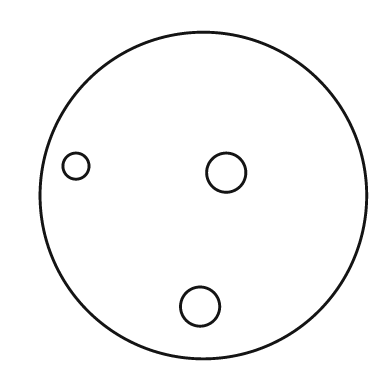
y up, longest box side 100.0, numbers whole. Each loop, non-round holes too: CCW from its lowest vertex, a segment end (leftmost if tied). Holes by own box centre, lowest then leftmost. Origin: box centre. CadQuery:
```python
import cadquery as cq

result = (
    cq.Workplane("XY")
    .moveTo(0.0, 0.0)
    .circle(50.0)
    .moveTo(-1.0, -34.0)
    .circle(6.0)
    .moveTo(7.0, 7.0)
    .circle(6.0)
    .moveTo(-39.0, 9.0)
    .circle(4.0)
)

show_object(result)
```